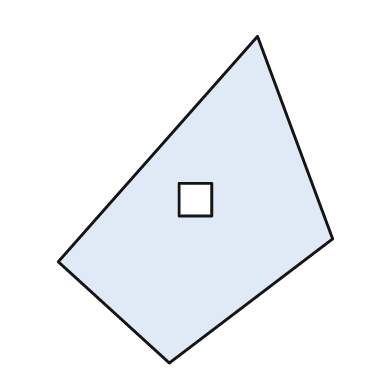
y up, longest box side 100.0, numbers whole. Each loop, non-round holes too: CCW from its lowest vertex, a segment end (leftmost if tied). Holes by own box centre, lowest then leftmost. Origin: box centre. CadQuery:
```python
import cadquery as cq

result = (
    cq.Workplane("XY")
    .moveTo(-8.0, -50.0)
    .lineTo(42.0, -12.0)
    .lineTo(19.0, 50.0)
    .lineTo(-42.0, -19.0)
    .close()
    .moveTo(-5.0, -5.0)
    .lineTo(5.0, -5.0)
    .lineTo(5.0, 5.0)
    .lineTo(-5.0, 5.0)
    .close()
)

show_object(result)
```